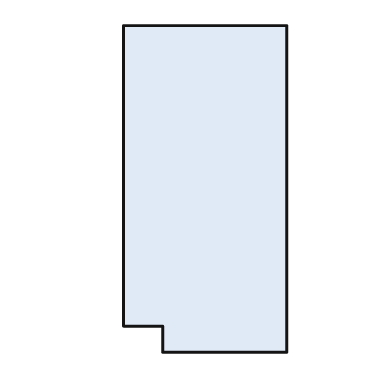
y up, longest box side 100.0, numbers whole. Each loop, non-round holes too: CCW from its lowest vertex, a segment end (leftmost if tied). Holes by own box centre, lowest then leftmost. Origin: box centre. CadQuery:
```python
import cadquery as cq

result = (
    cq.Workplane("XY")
    .moveTo(-13.0, -50.0)
    .lineTo(25.0, -50.0)
    .lineTo(25.0, 50.0)
    .lineTo(-25.0, 50.0)
    .lineTo(-25.0, -42.0)
    .lineTo(-13.0, -42.0)
    .close()
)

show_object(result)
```